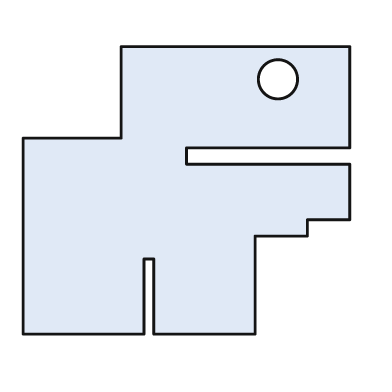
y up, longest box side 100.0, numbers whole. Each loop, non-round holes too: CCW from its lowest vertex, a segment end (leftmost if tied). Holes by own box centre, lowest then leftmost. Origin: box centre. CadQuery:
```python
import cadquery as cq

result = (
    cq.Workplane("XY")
    .moveTo(-50.0, -44.0)
    .lineTo(-13.0, -44.0)
    .lineTo(-13.0, -21.0)
    .lineTo(-10.0, -21.0)
    .lineTo(-10.0, -44.0)
    .lineTo(21.0, -44.0)
    .lineTo(21.0, -14.0)
    .lineTo(37.0, -14.0)
    .lineTo(37.0, -9.0)
    .lineTo(50.0, -9.0)
    .lineTo(50.0, 8.0)
    .lineTo(0.0, 8.0)
    .lineTo(0.0, 13.0)
    .lineTo(50.0, 13.0)
    .lineTo(50.0, 44.0)
    .lineTo(-20.0, 44.0)
    .lineTo(-20.0, 16.0)
    .lineTo(-50.0, 16.0)
    .close()
    .moveTo(28.0, 34.0)
    .circle(6.0)
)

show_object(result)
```